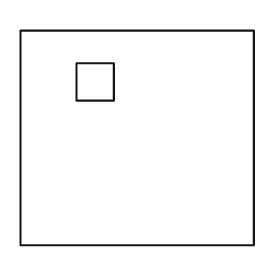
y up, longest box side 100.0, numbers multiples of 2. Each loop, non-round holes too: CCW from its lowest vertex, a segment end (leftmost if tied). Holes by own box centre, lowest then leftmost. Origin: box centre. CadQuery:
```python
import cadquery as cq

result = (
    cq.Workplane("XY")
    .moveTo(-50.0, -46.0)
    .lineTo(50.0, -46.0)
    .lineTo(50.0, 46.0)
    .lineTo(-50.0, 46.0)
    .close()
    .moveTo(-26.0, 16.0)
    .lineTo(-10.0, 16.0)
    .lineTo(-10.0, 32.0)
    .lineTo(-26.0, 32.0)
    .close()
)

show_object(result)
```